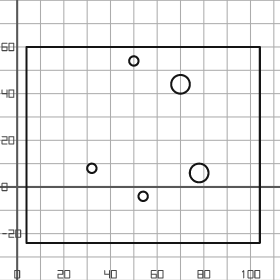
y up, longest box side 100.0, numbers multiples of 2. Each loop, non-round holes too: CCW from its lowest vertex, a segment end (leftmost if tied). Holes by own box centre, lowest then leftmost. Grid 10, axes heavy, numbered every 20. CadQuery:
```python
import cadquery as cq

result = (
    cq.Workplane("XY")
    .moveTo(4.0, -24.0)
    .lineTo(104.0, -24.0)
    .lineTo(104.0, 60.0)
    .lineTo(4.0, 60.0)
    .close()
    .moveTo(54.0, -4.0)
    .circle(2.0)
    .moveTo(78.0, 6.0)
    .circle(4.0)
    .moveTo(32.0, 8.0)
    .circle(2.0)
    .moveTo(70.0, 44.0)
    .circle(4.0)
    .moveTo(50.0, 54.0)
    .circle(2.0)
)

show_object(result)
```